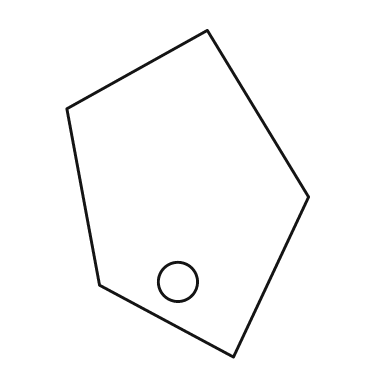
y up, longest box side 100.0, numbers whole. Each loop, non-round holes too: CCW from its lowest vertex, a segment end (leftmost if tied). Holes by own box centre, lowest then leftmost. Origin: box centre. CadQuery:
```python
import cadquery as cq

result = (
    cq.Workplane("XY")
    .moveTo(14.0, -50.0)
    .lineTo(37.0, -1.0)
    .lineTo(6.0, 50.0)
    .lineTo(-37.0, 26.0)
    .lineTo(-27.0, -28.0)
    .close()
    .moveTo(-3.0, -27.0)
    .circle(6.0)
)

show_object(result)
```